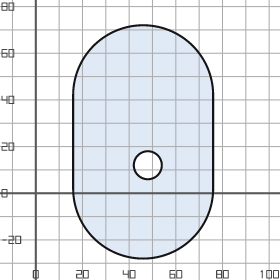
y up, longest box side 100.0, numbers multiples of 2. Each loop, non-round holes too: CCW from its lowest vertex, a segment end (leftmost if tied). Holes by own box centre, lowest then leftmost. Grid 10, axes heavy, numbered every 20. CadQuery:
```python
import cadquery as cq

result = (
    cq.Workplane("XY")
    .moveTo(16.0, 2.0)
    .threePointArc((46.0, -28.0), (76.0, 2.0))
    .lineTo(76.0, 42.0)
    .threePointArc((46.0, 72.0), (16.0, 42.0))
    .close()
    .moveTo(48.0, 12.0)
    .circle(6.0)
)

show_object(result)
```